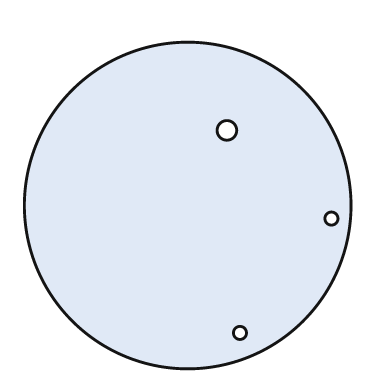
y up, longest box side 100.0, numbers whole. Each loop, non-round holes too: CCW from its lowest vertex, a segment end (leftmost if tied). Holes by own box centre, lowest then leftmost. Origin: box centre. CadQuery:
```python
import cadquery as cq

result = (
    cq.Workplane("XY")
    .moveTo(0.0, 0.0)
    .circle(50.0)
    .moveTo(16.0, -39.0)
    .circle(2.0)
    .moveTo(44.0, -4.0)
    .circle(2.0)
    .moveTo(12.0, 23.0)
    .circle(3.0)
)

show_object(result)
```